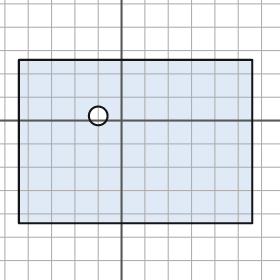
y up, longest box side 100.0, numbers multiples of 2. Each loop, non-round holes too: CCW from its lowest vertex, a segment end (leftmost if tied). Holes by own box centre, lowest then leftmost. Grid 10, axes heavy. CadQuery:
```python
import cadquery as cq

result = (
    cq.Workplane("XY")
    .moveTo(-44.0, -44.0)
    .lineTo(56.0, -44.0)
    .lineTo(56.0, 26.0)
    .lineTo(-44.0, 26.0)
    .close()
    .moveTo(-10.0, 2.0)
    .circle(4.0)
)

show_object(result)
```